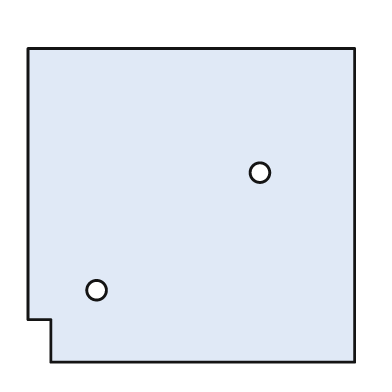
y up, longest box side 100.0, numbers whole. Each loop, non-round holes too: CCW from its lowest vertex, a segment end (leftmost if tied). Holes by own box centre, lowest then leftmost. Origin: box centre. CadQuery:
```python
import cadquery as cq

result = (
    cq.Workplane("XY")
    .moveTo(-43.0, -48.0)
    .lineTo(50.0, -48.0)
    .lineTo(50.0, 48.0)
    .lineTo(-50.0, 48.0)
    .lineTo(-50.0, -35.0)
    .lineTo(-43.0, -35.0)
    .close()
    .moveTo(-29.0, -26.0)
    .circle(3.0)
    .moveTo(21.0, 10.0)
    .circle(3.0)
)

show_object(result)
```